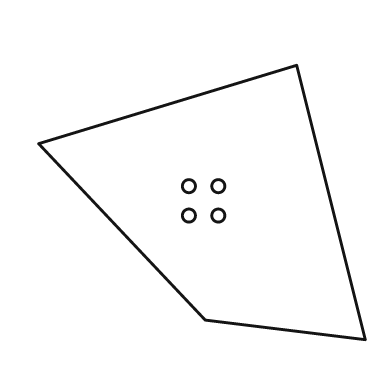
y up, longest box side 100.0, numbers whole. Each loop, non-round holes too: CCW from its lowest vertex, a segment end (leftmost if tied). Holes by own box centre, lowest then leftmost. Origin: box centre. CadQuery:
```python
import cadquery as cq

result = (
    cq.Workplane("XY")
    .moveTo(50.0, -42.0)
    .lineTo(29.0, 42.0)
    .lineTo(-50.0, 18.0)
    .lineTo(1.0, -36.0)
    .close()
    .moveTo(-4.0, -4.0)
    .circle(2.0)
    .moveTo(5.0, -4.0)
    .circle(2.0)
    .moveTo(-4.0, 5.0)
    .circle(2.0)
    .moveTo(5.0, 5.0)
    .circle(2.0)
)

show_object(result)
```